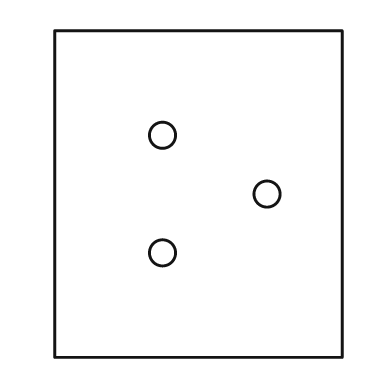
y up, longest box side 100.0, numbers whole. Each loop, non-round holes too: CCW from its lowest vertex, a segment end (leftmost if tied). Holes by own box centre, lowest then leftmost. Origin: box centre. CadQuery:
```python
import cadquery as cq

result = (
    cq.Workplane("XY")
    .moveTo(-44.0, -50.0)
    .lineTo(44.0, -50.0)
    .lineTo(44.0, 50.0)
    .lineTo(-44.0, 50.0)
    .close()
    .moveTo(-11.0, -18.0)
    .circle(4.0)
    .moveTo(21.0, 0.0)
    .circle(4.0)
    .moveTo(-11.0, 18.0)
    .circle(4.0)
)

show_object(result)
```